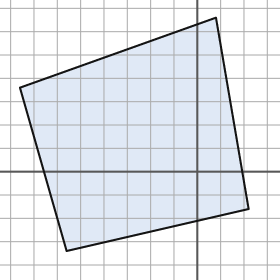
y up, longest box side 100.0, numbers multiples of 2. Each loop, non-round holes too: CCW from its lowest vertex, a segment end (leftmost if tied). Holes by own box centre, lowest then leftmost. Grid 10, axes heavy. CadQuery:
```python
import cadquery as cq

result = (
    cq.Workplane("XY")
    .moveTo(-56.0, -34.0)
    .lineTo(22.0, -16.0)
    .lineTo(8.0, 66.0)
    .lineTo(-76.0, 36.0)
    .close()
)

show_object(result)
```